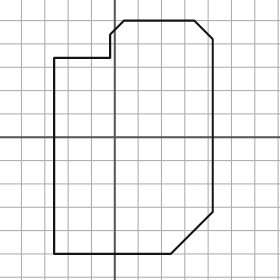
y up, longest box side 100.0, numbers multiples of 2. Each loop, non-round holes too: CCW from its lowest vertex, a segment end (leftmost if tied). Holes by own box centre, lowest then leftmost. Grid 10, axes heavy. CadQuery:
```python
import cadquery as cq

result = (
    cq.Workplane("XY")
    .moveTo(-26.0, -50.0)
    .lineTo(24.0, -50.0)
    .lineTo(42.0, -32.0)
    .lineTo(42.0, 42.0)
    .lineTo(34.0, 50.0)
    .lineTo(4.0, 50.0)
    .lineTo(-2.0, 44.0)
    .lineTo(-2.0, 34.0)
    .lineTo(-26.0, 34.0)
    .close()
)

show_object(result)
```